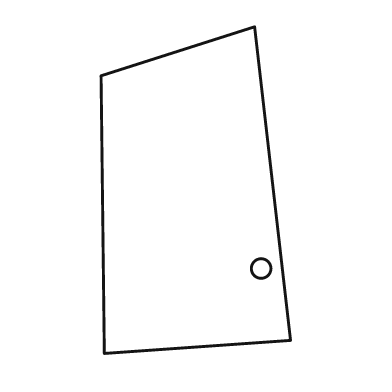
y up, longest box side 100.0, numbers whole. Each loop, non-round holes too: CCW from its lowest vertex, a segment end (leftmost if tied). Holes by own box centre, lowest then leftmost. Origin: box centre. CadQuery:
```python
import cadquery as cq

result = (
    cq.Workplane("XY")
    .moveTo(-28.0, -50.0)
    .lineTo(29.0, -46.0)
    .lineTo(18.0, 50.0)
    .lineTo(-29.0, 35.0)
    .close()
    .moveTo(20.0, -24.0)
    .circle(3.0)
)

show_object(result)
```